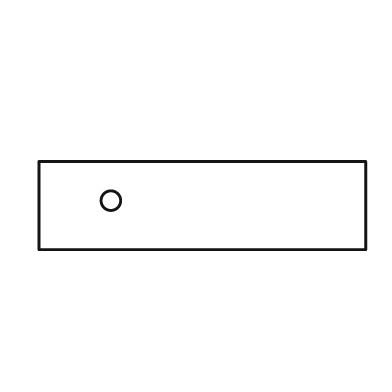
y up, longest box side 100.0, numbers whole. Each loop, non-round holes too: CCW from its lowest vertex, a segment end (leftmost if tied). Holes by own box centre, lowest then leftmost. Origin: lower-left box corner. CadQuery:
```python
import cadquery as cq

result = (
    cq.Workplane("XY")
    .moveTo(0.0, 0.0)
    .lineTo(100.0, 0.0)
    .lineTo(100.0, 27.0)
    .lineTo(0.0, 27.0)
    .close()
    .moveTo(22.0, 15.0)
    .circle(3.0)
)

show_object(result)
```